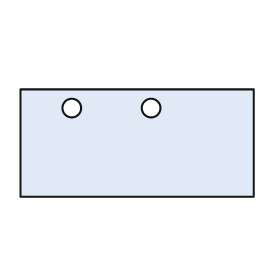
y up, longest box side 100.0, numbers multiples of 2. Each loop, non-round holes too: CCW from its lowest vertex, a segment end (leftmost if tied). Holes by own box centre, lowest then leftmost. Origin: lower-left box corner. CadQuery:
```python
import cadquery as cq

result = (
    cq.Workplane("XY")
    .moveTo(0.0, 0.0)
    .lineTo(100.0, 0.0)
    .lineTo(100.0, 46.0)
    .lineTo(0.0, 46.0)
    .close()
    .moveTo(22.0, 38.0)
    .circle(4.0)
    .moveTo(56.0, 38.0)
    .circle(4.0)
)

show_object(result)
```